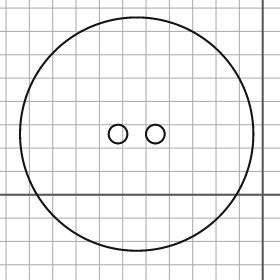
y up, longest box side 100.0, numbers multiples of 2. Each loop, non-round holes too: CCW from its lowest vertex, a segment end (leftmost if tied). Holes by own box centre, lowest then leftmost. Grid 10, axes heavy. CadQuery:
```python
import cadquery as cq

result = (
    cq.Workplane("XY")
    .moveTo(-54.0, 26.0)
    .circle(50.0)
    .moveTo(-62.0, 26.0)
    .circle(4.0)
    .moveTo(-46.0, 26.0)
    .circle(4.0)
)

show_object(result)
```